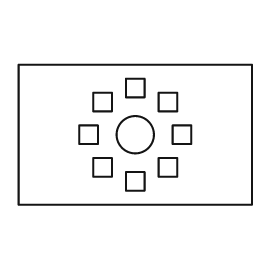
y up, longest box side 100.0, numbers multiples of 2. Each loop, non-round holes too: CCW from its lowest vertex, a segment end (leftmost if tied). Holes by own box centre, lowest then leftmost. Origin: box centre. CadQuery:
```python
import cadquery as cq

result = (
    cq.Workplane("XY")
    .moveTo(-50.0, -30.0)
    .lineTo(50.0, -30.0)
    .lineTo(50.0, 30.0)
    .lineTo(-50.0, 30.0)
    .close()
    .moveTo(-4.0, -24.0)
    .lineTo(4.0, -24.0)
    .lineTo(4.0, -16.0)
    .lineTo(-4.0, -16.0)
    .close()
    .moveTo(-18.0, -18.0)
    .lineTo(-10.0, -18.0)
    .lineTo(-10.0, -10.0)
    .lineTo(-18.0, -10.0)
    .close()
    .moveTo(10.0, -18.0)
    .lineTo(18.0, -18.0)
    .lineTo(18.0, -10.0)
    .lineTo(10.0, -10.0)
    .close()
    .moveTo(-24.0, -4.0)
    .lineTo(-16.0, -4.0)
    .lineTo(-16.0, 4.0)
    .lineTo(-24.0, 4.0)
    .close()
    .moveTo(0.0, 0.0)
    .circle(8.0)
    .moveTo(16.0, -4.0)
    .lineTo(24.0, -4.0)
    .lineTo(24.0, 4.0)
    .lineTo(16.0, 4.0)
    .close()
    .moveTo(-18.0, 10.0)
    .lineTo(-10.0, 10.0)
    .lineTo(-10.0, 18.0)
    .lineTo(-18.0, 18.0)
    .close()
    .moveTo(10.0, 10.0)
    .lineTo(18.0, 10.0)
    .lineTo(18.0, 18.0)
    .lineTo(10.0, 18.0)
    .close()
    .moveTo(-4.0, 16.0)
    .lineTo(4.0, 16.0)
    .lineTo(4.0, 24.0)
    .lineTo(-4.0, 24.0)
    .close()
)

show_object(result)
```